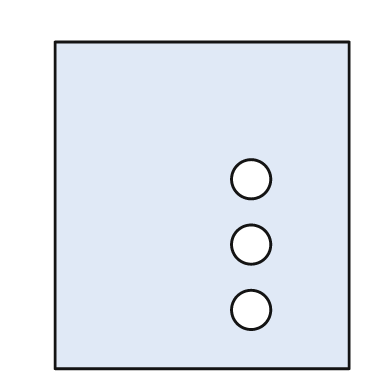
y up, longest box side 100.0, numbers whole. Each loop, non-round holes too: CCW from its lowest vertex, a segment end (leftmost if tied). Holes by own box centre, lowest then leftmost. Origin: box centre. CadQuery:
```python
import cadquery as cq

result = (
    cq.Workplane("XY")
    .moveTo(-45.0, -50.0)
    .lineTo(45.0, -50.0)
    .lineTo(45.0, 50.0)
    .lineTo(-45.0, 50.0)
    .close()
    .moveTo(15.0, -32.0)
    .circle(6.0)
    .moveTo(15.0, -12.0)
    .circle(6.0)
    .moveTo(15.0, 8.0)
    .circle(6.0)
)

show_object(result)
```